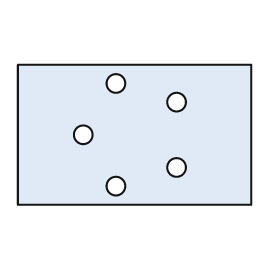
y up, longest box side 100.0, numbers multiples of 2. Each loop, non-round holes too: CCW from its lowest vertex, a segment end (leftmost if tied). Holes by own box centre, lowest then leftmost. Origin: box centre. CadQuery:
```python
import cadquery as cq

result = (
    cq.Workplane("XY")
    .moveTo(-50.0, -30.0)
    .lineTo(50.0, -30.0)
    .lineTo(50.0, 30.0)
    .lineTo(-50.0, 30.0)
    .close()
    .moveTo(-8.0, -22.0)
    .circle(4.0)
    .moveTo(18.0, -14.0)
    .circle(4.0)
    .moveTo(-22.0, 0.0)
    .circle(4.0)
    .moveTo(18.0, 14.0)
    .circle(4.0)
    .moveTo(-8.0, 22.0)
    .circle(4.0)
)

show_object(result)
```